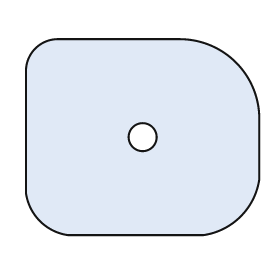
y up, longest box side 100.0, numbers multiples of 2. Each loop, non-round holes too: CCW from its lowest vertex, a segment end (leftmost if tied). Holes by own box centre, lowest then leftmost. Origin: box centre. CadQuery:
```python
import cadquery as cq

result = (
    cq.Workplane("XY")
    .moveTo(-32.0, -42.0)
    .lineTo(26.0, -42.0)
    .threePointArc((42.0, -34.0), (50.0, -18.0))
    .lineTo(50.0, 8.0)
    .threePointArc((40.0, 32.0), (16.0, 42.0))
    .lineTo(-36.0, 42.0)
    .threePointArc((-46.0, 38.0), (-50.0, 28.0))
    .lineTo(-50.0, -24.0)
    .threePointArc((-44.0, -36.0), (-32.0, -42.0))
    .close()
    .moveTo(0.0, 0.0)
    .circle(6.0)
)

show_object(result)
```